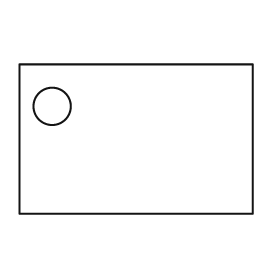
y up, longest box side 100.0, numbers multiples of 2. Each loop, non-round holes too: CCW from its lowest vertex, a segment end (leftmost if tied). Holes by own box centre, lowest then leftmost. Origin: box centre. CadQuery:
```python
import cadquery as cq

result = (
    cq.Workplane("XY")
    .moveTo(-50.0, -32.0)
    .lineTo(50.0, -32.0)
    .lineTo(50.0, 32.0)
    .lineTo(-50.0, 32.0)
    .close()
    .moveTo(-36.0, 14.0)
    .circle(8.0)
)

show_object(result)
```